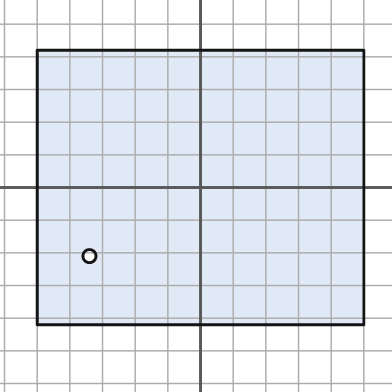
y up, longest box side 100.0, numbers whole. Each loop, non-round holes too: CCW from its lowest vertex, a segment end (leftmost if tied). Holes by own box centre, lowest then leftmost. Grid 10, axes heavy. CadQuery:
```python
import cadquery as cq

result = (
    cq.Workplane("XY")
    .moveTo(-50.0, -42.0)
    .lineTo(50.0, -42.0)
    .lineTo(50.0, 42.0)
    .lineTo(-50.0, 42.0)
    .close()
    .moveTo(-34.0, -21.0)
    .circle(2.0)
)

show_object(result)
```